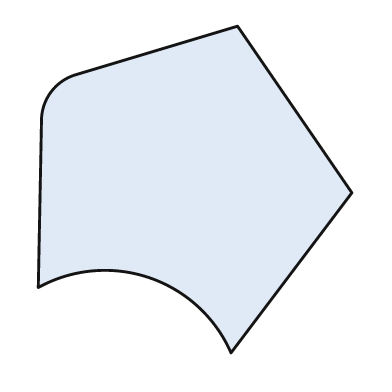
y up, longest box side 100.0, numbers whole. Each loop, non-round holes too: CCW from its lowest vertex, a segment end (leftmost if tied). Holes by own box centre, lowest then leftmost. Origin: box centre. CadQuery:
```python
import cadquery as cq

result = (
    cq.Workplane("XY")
    .moveTo(11.0, -50.0)
    .lineTo(48.0, -1.0)
    .lineTo(13.0, 50.0)
    .lineTo(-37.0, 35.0)
    .threePointArc((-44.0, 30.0), (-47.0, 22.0))
    .lineTo(-48.0, -30.0)
    .threePointArc((-14.0, -27.0), (11.0, -50.0))
    .close()
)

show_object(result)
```